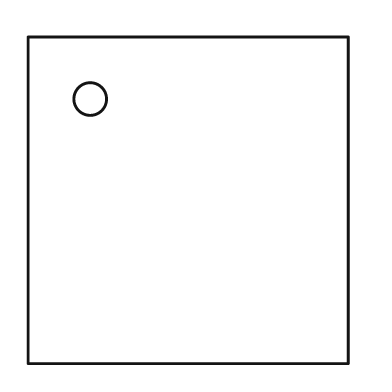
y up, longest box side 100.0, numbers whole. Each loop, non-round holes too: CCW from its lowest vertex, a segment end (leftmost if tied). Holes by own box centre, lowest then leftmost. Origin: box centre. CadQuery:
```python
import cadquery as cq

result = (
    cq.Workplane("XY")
    .moveTo(-49.0, -50.0)
    .lineTo(49.0, -50.0)
    .lineTo(49.0, 50.0)
    .lineTo(-49.0, 50.0)
    .close()
    .moveTo(-30.0, 31.0)
    .circle(5.0)
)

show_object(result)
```